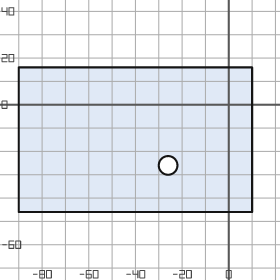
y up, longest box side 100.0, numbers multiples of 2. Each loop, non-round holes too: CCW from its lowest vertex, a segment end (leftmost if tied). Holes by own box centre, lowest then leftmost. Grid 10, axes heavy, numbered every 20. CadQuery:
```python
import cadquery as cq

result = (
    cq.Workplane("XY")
    .moveTo(-90.0, -46.0)
    .lineTo(10.0, -46.0)
    .lineTo(10.0, 16.0)
    .lineTo(-90.0, 16.0)
    .close()
    .moveTo(-26.0, -26.0)
    .circle(4.0)
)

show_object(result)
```